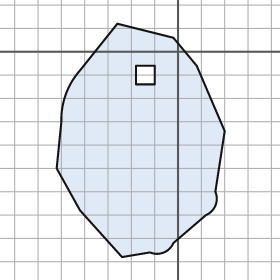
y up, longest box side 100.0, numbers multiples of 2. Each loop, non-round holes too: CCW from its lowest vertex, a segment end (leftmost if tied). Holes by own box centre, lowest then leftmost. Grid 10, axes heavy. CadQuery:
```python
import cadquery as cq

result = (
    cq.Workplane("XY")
    .moveTo(-24.0, -88.0)
    .lineTo(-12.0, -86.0)
    .threePointArc((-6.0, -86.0), (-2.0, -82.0))
    .lineTo(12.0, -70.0)
    .threePointArc((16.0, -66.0), (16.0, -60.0))
    .lineTo(20.0, -34.0)
    .lineTo(8.0, -6.0)
    .lineTo(-2.0, 6.0)
    .lineTo(-26.0, 12.0)
    .lineTo(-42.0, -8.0)
    .threePointArc((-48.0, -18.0), (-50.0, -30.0))
    .lineTo(-52.0, -50.0)
    .lineTo(-42.0, -68.0)
    .close()
    .moveTo(-18.0, -14.0)
    .lineTo(-10.0, -14.0)
    .lineTo(-10.0, -6.0)
    .lineTo(-18.0, -6.0)
    .close()
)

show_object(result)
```